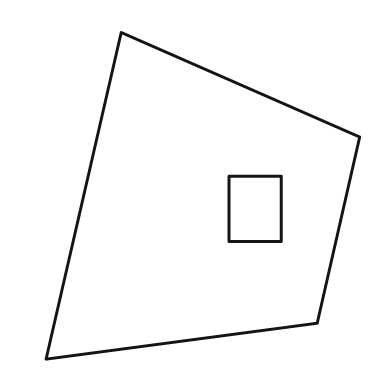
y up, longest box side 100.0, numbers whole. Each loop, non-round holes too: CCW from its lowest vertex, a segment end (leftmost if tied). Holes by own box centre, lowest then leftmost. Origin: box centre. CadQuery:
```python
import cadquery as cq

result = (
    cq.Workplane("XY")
    .moveTo(-48.0, -50.0)
    .lineTo(35.0, -39.0)
    .lineTo(48.0, 18.0)
    .lineTo(-25.0, 50.0)
    .close()
    .moveTo(8.0, -14.0)
    .lineTo(24.0, -14.0)
    .lineTo(24.0, 6.0)
    .lineTo(8.0, 6.0)
    .close()
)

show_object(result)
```